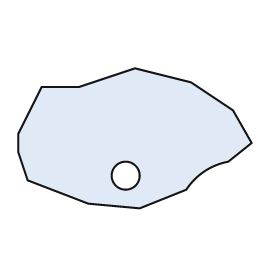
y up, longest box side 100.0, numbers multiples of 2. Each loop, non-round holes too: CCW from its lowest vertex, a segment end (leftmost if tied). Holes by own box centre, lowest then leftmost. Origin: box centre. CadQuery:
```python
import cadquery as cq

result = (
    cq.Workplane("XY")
    .moveTo(2.0, -30.0)
    .lineTo(22.0, -22.0)
    .threePointArc((30.0, -14.0), (40.0, -10.0))
    .lineTo(50.0, -2.0)
    .lineTo(42.0, 12.0)
    .lineTo(24.0, 24.0)
    .lineTo(0.0, 30.0)
    .lineTo(-24.0, 22.0)
    .lineTo(-40.0, 22.0)
    .lineTo(-50.0, 2.0)
    .lineTo(-50.0, -6.0)
    .lineTo(-46.0, -18.0)
    .lineTo(-20.0, -28.0)
    .close()
    .moveTo(-4.0, -16.0)
    .circle(6.0)
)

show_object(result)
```